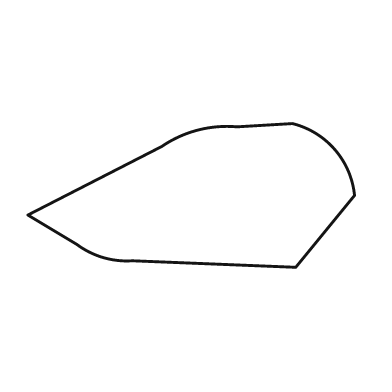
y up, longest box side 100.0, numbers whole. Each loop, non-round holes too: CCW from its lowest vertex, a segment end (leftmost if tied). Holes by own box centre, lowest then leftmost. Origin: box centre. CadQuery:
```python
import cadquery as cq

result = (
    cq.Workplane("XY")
    .moveTo(32.0, -22.0)
    .lineTo(50.0, 0.0)
    .threePointArc((44.0, 14.0), (31.0, 22.0))
    .lineTo(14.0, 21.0)
    .threePointArc((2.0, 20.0), (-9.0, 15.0))
    .lineTo(-50.0, -6.0)
    .lineTo(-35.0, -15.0)
    .threePointArc((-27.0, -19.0), (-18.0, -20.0))
    .close()
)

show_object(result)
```